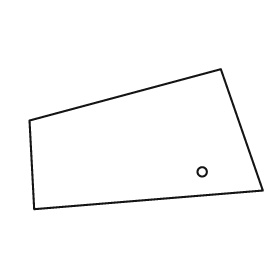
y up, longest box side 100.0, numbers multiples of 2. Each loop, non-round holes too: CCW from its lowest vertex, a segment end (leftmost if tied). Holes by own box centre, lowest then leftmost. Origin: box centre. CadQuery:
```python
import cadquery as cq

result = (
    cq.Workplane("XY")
    .moveTo(-48.0, -30.0)
    .lineTo(50.0, -22.0)
    .lineTo(32.0, 30.0)
    .lineTo(-50.0, 8.0)
    .close()
    .moveTo(24.0, -14.0)
    .circle(2.0)
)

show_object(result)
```